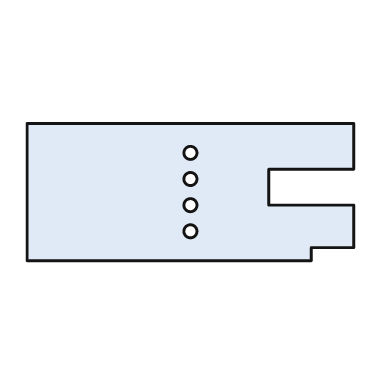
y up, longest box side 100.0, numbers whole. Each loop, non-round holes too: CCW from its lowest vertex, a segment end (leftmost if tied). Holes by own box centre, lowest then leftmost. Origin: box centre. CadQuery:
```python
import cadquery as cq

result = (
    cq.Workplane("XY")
    .moveTo(-50.0, -21.0)
    .lineTo(37.0, -21.0)
    .lineTo(37.0, -17.0)
    .lineTo(50.0, -17.0)
    .lineTo(50.0, -4.0)
    .lineTo(24.0, -4.0)
    .lineTo(24.0, 7.0)
    .lineTo(50.0, 7.0)
    .lineTo(50.0, 21.0)
    .lineTo(-50.0, 21.0)
    .close()
    .moveTo(0.0, -12.0)
    .circle(2.0)
    .moveTo(0.0, -4.0)
    .circle(2.0)
    .moveTo(0.0, 4.0)
    .circle(2.0)
    .moveTo(0.0, 12.0)
    .circle(2.0)
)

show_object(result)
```